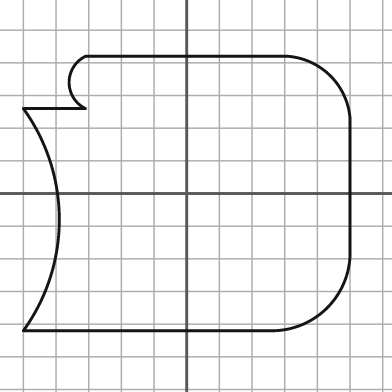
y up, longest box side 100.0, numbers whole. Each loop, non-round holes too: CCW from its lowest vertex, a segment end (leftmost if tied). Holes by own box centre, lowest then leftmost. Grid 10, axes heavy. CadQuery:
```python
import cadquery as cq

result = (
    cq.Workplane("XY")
    .moveTo(-50.0, -42.0)
    .lineTo(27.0, -42.0)
    .threePointArc((43.0, -35.0), (50.0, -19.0))
    .lineTo(50.0, 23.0)
    .threePointArc((44.0, 36.0), (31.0, 42.0))
    .lineTo(-31.0, 42.0)
    .threePointArc((-36.0, 34.0), (-31.0, 26.0))
    .lineTo(-50.0, 26.0)
    .threePointArc((-39.0, -8.0), (-50.0, -42.0))
    .close()
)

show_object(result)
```